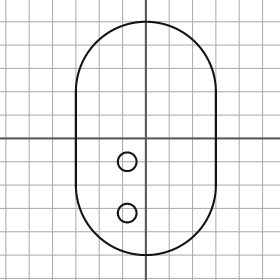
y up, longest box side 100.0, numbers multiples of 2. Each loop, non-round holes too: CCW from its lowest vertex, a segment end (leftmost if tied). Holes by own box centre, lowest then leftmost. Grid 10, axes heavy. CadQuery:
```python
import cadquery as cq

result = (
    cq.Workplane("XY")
    .moveTo(-30.0, -20.0)
    .threePointArc((0.0, -50.0), (30.0, -20.0))
    .lineTo(30.0, 20.0)
    .threePointArc((0.0, 50.0), (-30.0, 20.0))
    .close()
    .moveTo(-8.0, -32.0)
    .circle(4.0)
    .moveTo(-8.0, -10.0)
    .circle(4.0)
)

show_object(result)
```